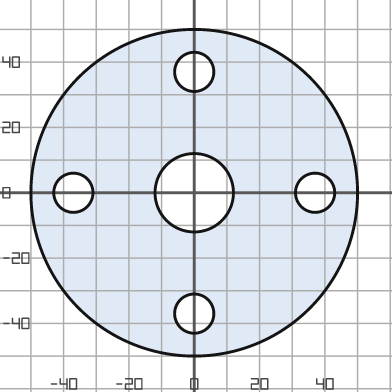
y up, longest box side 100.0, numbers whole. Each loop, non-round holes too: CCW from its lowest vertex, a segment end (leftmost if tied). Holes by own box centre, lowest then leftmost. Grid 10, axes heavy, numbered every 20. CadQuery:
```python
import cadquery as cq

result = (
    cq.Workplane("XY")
    .moveTo(0.0, 0.0)
    .circle(50.0)
    .moveTo(0.0, -37.0)
    .circle(6.0)
    .moveTo(-37.0, 0.0)
    .circle(6.0)
    .moveTo(0.0, 0.0)
    .circle(12.0)
    .moveTo(37.0, 0.0)
    .circle(6.0)
    .moveTo(0.0, 37.0)
    .circle(6.0)
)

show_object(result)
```